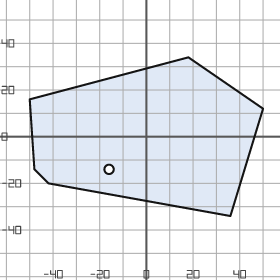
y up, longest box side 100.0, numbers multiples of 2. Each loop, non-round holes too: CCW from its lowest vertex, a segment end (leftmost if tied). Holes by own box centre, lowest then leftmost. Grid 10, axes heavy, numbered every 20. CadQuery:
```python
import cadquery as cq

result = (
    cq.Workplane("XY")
    .moveTo(36.0, -34.0)
    .lineTo(50.0, 12.0)
    .lineTo(18.0, 34.0)
    .lineTo(-50.0, 16.0)
    .lineTo(-48.0, -14.0)
    .lineTo(-42.0, -20.0)
    .close()
    .moveTo(-16.0, -14.0)
    .circle(2.0)
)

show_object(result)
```